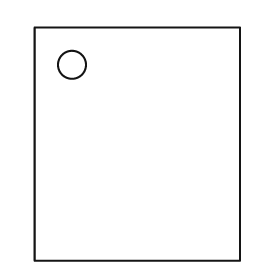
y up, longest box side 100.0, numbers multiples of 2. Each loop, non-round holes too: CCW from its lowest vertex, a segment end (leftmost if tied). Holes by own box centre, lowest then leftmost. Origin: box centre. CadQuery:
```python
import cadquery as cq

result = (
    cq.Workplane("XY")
    .moveTo(-44.0, -50.0)
    .lineTo(44.0, -50.0)
    .lineTo(44.0, 50.0)
    .lineTo(-44.0, 50.0)
    .close()
    .moveTo(-28.0, 34.0)
    .circle(6.0)
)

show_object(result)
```